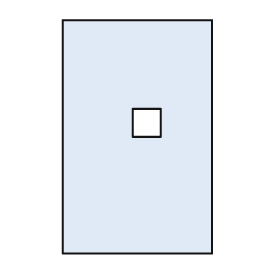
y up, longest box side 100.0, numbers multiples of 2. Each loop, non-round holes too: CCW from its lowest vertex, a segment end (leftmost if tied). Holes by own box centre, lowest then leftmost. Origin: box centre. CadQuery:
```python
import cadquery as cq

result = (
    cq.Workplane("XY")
    .moveTo(-32.0, -50.0)
    .lineTo(32.0, -50.0)
    .lineTo(32.0, 50.0)
    .lineTo(-32.0, 50.0)
    .close()
    .moveTo(-2.0, 0.0)
    .lineTo(10.0, 0.0)
    .lineTo(10.0, 12.0)
    .lineTo(-2.0, 12.0)
    .close()
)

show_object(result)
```